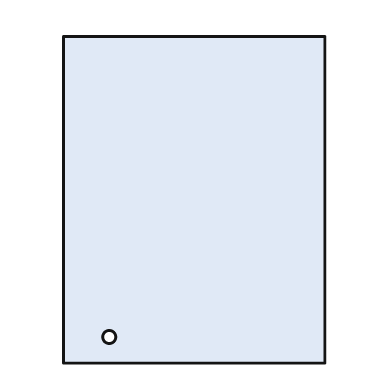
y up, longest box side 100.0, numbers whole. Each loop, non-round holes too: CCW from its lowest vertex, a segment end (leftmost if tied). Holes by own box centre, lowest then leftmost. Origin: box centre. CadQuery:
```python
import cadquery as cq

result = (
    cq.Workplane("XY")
    .moveTo(-40.0, -50.0)
    .lineTo(40.0, -50.0)
    .lineTo(40.0, 50.0)
    .lineTo(-40.0, 50.0)
    .close()
    .moveTo(-26.0, -42.0)
    .circle(2.0)
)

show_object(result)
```